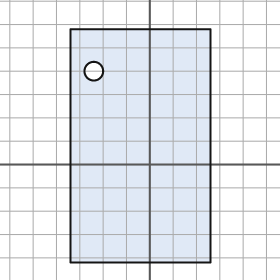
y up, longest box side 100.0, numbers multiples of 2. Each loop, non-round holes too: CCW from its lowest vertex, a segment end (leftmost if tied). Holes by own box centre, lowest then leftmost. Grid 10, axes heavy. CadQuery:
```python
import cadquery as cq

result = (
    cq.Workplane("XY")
    .moveTo(-34.0, -42.0)
    .lineTo(26.0, -42.0)
    .lineTo(26.0, 58.0)
    .lineTo(-34.0, 58.0)
    .close()
    .moveTo(-24.0, 40.0)
    .circle(4.0)
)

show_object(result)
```